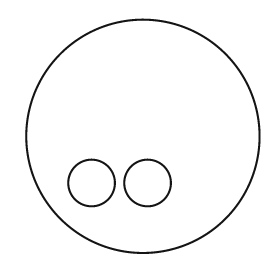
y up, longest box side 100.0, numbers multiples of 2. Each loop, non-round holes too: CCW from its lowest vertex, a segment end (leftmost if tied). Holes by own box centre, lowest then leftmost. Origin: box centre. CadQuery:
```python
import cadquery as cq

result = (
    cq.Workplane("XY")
    .moveTo(0.0, 0.0)
    .circle(50.0)
    .moveTo(-22.0, -20.0)
    .circle(10.0)
    .moveTo(2.0, -20.0)
    .circle(10.0)
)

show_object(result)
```